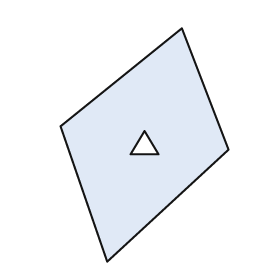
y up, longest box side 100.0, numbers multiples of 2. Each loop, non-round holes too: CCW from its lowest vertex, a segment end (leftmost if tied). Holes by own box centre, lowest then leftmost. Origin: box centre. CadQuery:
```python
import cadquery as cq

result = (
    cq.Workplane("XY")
    .moveTo(-16.0, -50.0)
    .lineTo(36.0, -2.0)
    .lineTo(16.0, 50.0)
    .lineTo(-36.0, 8.0)
    .close()
    .moveTo(-6.0, -4.0)
    .lineTo(6.0, -4.0)
    .lineTo(0.0, 6.0)
    .close()
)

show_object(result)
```